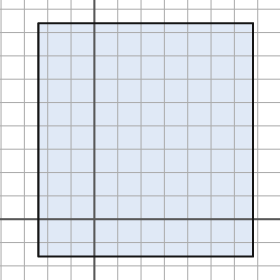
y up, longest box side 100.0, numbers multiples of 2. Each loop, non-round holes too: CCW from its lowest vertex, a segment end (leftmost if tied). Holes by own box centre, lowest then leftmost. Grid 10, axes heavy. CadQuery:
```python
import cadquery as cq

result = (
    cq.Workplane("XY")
    .moveTo(-24.0, -16.0)
    .lineTo(68.0, -16.0)
    .lineTo(68.0, 84.0)
    .lineTo(-24.0, 84.0)
    .close()
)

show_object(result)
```